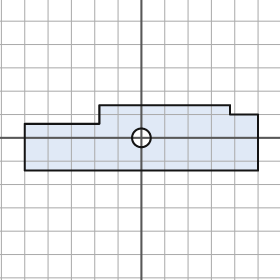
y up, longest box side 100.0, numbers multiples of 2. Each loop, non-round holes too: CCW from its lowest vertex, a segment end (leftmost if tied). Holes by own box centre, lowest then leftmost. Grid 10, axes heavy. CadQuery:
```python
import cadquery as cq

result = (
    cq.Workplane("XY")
    .moveTo(-50.0, -14.0)
    .lineTo(50.0, -14.0)
    .lineTo(50.0, 10.0)
    .lineTo(38.0, 10.0)
    .lineTo(38.0, 14.0)
    .lineTo(-18.0, 14.0)
    .lineTo(-18.0, 6.0)
    .lineTo(-50.0, 6.0)
    .close()
    .moveTo(0.0, 0.0)
    .circle(4.0)
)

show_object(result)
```